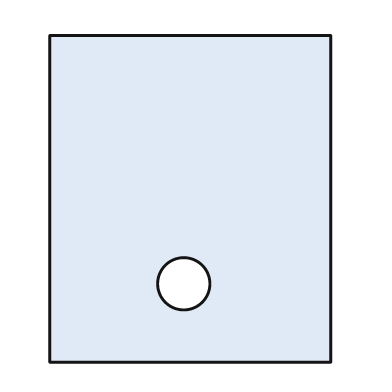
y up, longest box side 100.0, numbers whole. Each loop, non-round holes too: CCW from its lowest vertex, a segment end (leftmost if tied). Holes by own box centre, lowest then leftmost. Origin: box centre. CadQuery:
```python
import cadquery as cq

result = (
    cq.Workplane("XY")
    .moveTo(-43.0, -50.0)
    .lineTo(43.0, -50.0)
    .lineTo(43.0, 50.0)
    .lineTo(-43.0, 50.0)
    .close()
    .moveTo(-2.0, -26.0)
    .circle(8.0)
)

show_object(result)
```